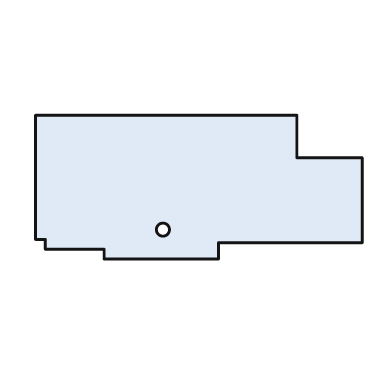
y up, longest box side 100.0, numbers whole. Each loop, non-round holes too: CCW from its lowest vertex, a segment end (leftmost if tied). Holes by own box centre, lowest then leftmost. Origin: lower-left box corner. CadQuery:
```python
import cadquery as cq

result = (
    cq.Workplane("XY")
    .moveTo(21.0, 0.0)
    .lineTo(56.0, 0.0)
    .lineTo(56.0, 5.0)
    .lineTo(100.0, 5.0)
    .lineTo(100.0, 31.0)
    .lineTo(80.0, 31.0)
    .lineTo(80.0, 44.0)
    .lineTo(0.0, 44.0)
    .lineTo(0.0, 6.0)
    .lineTo(3.0, 6.0)
    .lineTo(3.0, 3.0)
    .lineTo(21.0, 3.0)
    .close()
    .moveTo(39.0, 9.0)
    .circle(2.0)
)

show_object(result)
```